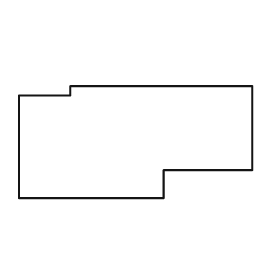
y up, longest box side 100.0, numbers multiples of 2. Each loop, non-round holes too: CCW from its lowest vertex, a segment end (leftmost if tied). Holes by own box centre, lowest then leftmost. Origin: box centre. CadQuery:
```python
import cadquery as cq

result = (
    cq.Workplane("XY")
    .moveTo(-50.0, -24.0)
    .lineTo(12.0, -24.0)
    .lineTo(12.0, -12.0)
    .lineTo(50.0, -12.0)
    .lineTo(50.0, 24.0)
    .lineTo(-28.0, 24.0)
    .lineTo(-28.0, 20.0)
    .lineTo(-50.0, 20.0)
    .close()
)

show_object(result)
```